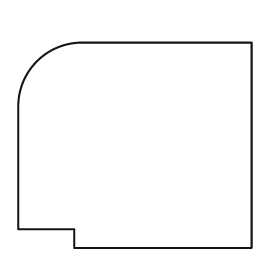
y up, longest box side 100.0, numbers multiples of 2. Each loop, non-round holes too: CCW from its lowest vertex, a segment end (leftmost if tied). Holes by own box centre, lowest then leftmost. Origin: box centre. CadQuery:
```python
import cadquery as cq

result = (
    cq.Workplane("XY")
    .moveTo(-26.0, -44.0)
    .lineTo(50.0, -44.0)
    .lineTo(50.0, 44.0)
    .lineTo(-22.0, 44.0)
    .threePointArc((-42.0, 36.0), (-50.0, 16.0))
    .lineTo(-50.0, -36.0)
    .lineTo(-26.0, -36.0)
    .close()
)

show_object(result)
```